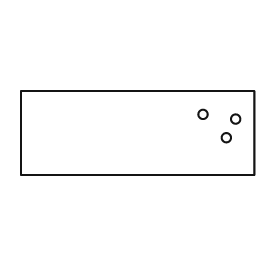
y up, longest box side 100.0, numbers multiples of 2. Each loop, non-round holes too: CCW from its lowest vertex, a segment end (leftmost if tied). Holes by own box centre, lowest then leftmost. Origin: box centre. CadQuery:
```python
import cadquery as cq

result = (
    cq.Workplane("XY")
    .moveTo(-50.0, -18.0)
    .lineTo(50.0, -18.0)
    .lineTo(50.0, 18.0)
    .lineTo(-50.0, 18.0)
    .close()
    .moveTo(38.0, -2.0)
    .circle(2.0)
    .moveTo(42.0, 6.0)
    .circle(2.0)
    .moveTo(28.0, 8.0)
    .circle(2.0)
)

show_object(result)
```